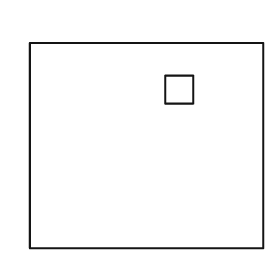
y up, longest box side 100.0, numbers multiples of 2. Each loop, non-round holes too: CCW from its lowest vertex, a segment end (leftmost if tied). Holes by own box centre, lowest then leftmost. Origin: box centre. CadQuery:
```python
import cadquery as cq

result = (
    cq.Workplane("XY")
    .moveTo(-50.0, -44.0)
    .lineTo(50.0, -44.0)
    .lineTo(50.0, 44.0)
    .lineTo(-50.0, 44.0)
    .close()
    .moveTo(8.0, 18.0)
    .lineTo(20.0, 18.0)
    .lineTo(20.0, 30.0)
    .lineTo(8.0, 30.0)
    .close()
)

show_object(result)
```